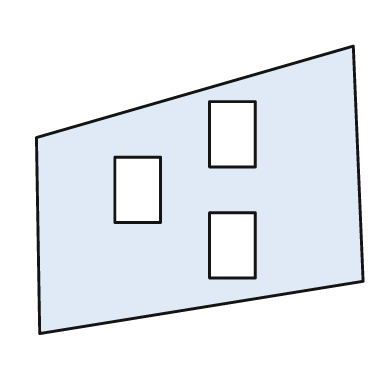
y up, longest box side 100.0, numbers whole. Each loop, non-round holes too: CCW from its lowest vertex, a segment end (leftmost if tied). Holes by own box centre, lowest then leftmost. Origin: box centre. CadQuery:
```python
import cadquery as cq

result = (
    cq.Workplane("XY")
    .moveTo(-49.0, -44.0)
    .lineTo(50.0, -28.0)
    .lineTo(47.0, 44.0)
    .lineTo(-50.0, 16.0)
    .close()
    .moveTo(3.0, -27.0)
    .lineTo(17.0, -27.0)
    .lineTo(17.0, -7.0)
    .lineTo(3.0, -7.0)
    .close()
    .moveTo(-26.0, -10.0)
    .lineTo(-12.0, -10.0)
    .lineTo(-12.0, 10.0)
    .lineTo(-26.0, 10.0)
    .close()
    .moveTo(3.0, 7.0)
    .lineTo(17.0, 7.0)
    .lineTo(17.0, 27.0)
    .lineTo(3.0, 27.0)
    .close()
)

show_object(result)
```